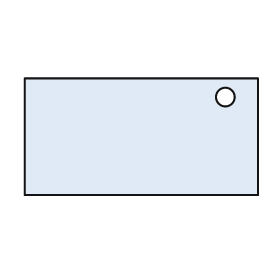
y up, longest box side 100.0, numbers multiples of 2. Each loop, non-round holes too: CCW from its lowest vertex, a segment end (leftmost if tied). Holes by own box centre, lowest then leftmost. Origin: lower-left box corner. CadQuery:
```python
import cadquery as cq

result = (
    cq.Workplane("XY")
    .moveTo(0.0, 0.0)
    .lineTo(100.0, 0.0)
    .lineTo(100.0, 50.0)
    .lineTo(0.0, 50.0)
    .close()
    .moveTo(86.0, 42.0)
    .circle(4.0)
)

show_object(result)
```